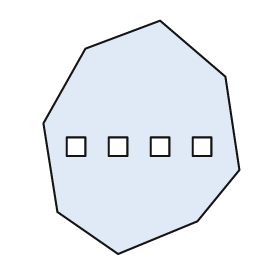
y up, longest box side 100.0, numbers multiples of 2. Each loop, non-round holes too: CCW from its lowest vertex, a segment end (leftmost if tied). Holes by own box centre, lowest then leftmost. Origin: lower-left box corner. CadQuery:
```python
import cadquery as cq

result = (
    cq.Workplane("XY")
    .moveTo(32.0, 0.0)
    .lineTo(66.0, 14.0)
    .lineTo(84.0, 36.0)
    .lineTo(78.0, 76.0)
    .lineTo(50.0, 100.0)
    .lineTo(18.0, 88.0)
    .lineTo(0.0, 56.0)
    .lineTo(6.0, 18.0)
    .close()
    .moveTo(10.0, 42.0)
    .lineTo(18.0, 42.0)
    .lineTo(18.0, 50.0)
    .lineTo(10.0, 50.0)
    .close()
    .moveTo(28.0, 42.0)
    .lineTo(36.0, 42.0)
    .lineTo(36.0, 50.0)
    .lineTo(28.0, 50.0)
    .close()
    .moveTo(46.0, 42.0)
    .lineTo(54.0, 42.0)
    .lineTo(54.0, 50.0)
    .lineTo(46.0, 50.0)
    .close()
    .moveTo(64.0, 42.0)
    .lineTo(72.0, 42.0)
    .lineTo(72.0, 50.0)
    .lineTo(64.0, 50.0)
    .close()
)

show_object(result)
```